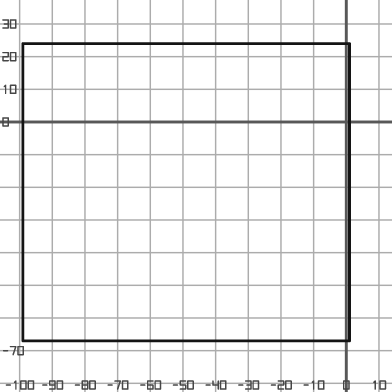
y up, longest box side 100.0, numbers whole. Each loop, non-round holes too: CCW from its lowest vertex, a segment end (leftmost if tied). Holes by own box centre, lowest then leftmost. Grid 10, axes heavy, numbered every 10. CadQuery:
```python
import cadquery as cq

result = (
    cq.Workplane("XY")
    .moveTo(-99.0, -67.0)
    .lineTo(1.0, -67.0)
    .lineTo(1.0, 24.0)
    .lineTo(-99.0, 24.0)
    .close()
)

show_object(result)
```